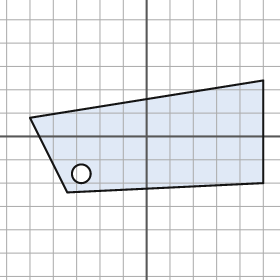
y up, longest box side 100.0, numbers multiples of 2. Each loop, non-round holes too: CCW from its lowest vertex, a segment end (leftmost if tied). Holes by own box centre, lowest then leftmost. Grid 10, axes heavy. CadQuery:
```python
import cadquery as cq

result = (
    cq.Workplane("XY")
    .moveTo(-34.0, -24.0)
    .lineTo(50.0, -20.0)
    .lineTo(50.0, 24.0)
    .lineTo(-50.0, 8.0)
    .close()
    .moveTo(-28.0, -16.0)
    .circle(4.0)
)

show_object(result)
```